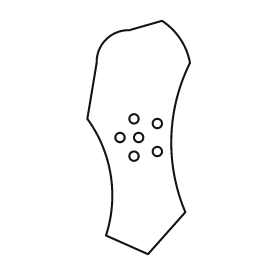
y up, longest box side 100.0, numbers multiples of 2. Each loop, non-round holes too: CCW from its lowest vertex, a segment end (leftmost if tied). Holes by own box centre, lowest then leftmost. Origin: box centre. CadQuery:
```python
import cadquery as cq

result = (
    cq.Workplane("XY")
    .moveTo(4.0, -50.0)
    .lineTo(20.0, -32.0)
    .threePointArc((14.0, 0.0), (22.0, 32.0))
    .threePointArc((18.0, 42.0), (10.0, 50.0))
    .lineTo(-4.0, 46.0)
    .threePointArc((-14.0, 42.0), (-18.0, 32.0))
    .lineTo(-22.0, 8.0)
    .threePointArc((-12.0, -16.0), (-14.0, -42.0))
    .close()
    .moveTo(-2.0, -8.0)
    .circle(2.0)
    .moveTo(8.0, -6.0)
    .circle(2.0)
    .moveTo(-8.0, 0.0)
    .circle(2.0)
    .moveTo(0.0, 0.0)
    .circle(2.0)
    .moveTo(8.0, 6.0)
    .circle(2.0)
    .moveTo(-2.0, 8.0)
    .circle(2.0)
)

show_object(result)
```